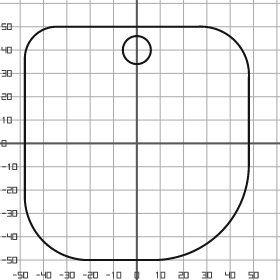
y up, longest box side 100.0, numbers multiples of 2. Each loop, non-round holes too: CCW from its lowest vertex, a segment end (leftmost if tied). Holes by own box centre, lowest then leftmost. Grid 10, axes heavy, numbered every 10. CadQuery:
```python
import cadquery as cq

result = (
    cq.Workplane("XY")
    .moveTo(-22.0, -50.0)
    .lineTo(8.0, -50.0)
    .threePointArc((36.0, -38.0), (48.0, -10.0))
    .lineTo(48.0, 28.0)
    .threePointArc((42.0, 44.0), (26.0, 50.0))
    .lineTo(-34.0, 50.0)
    .threePointArc((-44.0, 46.0), (-48.0, 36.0))
    .lineTo(-48.0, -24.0)
    .threePointArc((-40.0, -42.0), (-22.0, -50.0))
    .close()
    .moveTo(0.0, 40.0)
    .circle(6.0)
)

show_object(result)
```